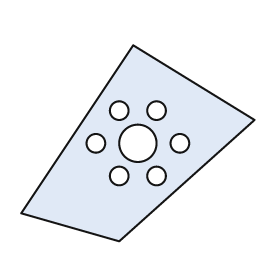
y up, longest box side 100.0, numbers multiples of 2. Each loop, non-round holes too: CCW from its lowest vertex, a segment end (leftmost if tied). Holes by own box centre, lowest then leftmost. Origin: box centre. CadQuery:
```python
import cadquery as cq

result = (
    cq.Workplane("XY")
    .moveTo(-8.0, -42.0)
    .lineTo(50.0, 10.0)
    .lineTo(-2.0, 42.0)
    .lineTo(-50.0, -30.0)
    .close()
    .moveTo(-8.0, -14.0)
    .circle(4.0)
    .moveTo(8.0, -14.0)
    .circle(4.0)
    .moveTo(-18.0, 0.0)
    .circle(4.0)
    .moveTo(0.0, 0.0)
    .circle(8.0)
    .moveTo(18.0, 0.0)
    .circle(4.0)
    .moveTo(-8.0, 14.0)
    .circle(4.0)
    .moveTo(8.0, 14.0)
    .circle(4.0)
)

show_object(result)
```